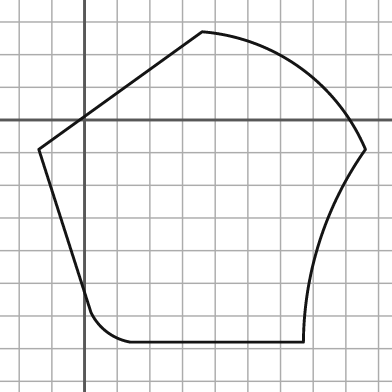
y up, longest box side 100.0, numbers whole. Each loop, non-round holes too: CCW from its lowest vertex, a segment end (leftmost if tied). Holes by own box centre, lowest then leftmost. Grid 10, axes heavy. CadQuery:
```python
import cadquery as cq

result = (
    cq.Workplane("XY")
    .moveTo(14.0, -68.0)
    .lineTo(67.0, -68.0)
    .threePointArc((72.0, -37.0), (86.0, -9.0))
    .threePointArc((66.0, 16.0), (36.0, 27.0))
    .lineTo(-14.0, -9.0)
    .lineTo(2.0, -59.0)
    .threePointArc((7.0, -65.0), (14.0, -68.0))
    .close()
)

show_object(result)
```